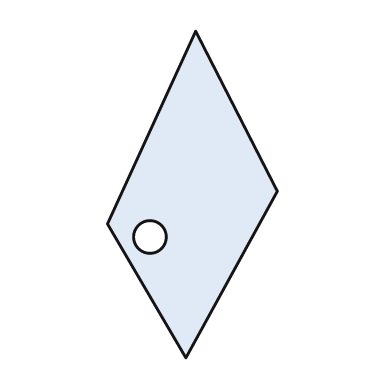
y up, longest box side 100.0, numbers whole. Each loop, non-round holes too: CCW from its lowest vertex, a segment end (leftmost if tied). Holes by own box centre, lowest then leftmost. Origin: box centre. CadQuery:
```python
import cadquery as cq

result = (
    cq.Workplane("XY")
    .moveTo(-2.0, -50.0)
    .lineTo(26.0, 1.0)
    .lineTo(1.0, 50.0)
    .lineTo(-26.0, -9.0)
    .close()
    .moveTo(-13.0, -13.0)
    .circle(5.0)
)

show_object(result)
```